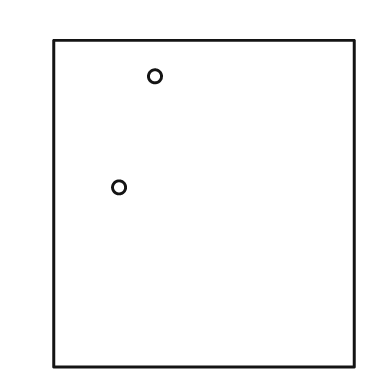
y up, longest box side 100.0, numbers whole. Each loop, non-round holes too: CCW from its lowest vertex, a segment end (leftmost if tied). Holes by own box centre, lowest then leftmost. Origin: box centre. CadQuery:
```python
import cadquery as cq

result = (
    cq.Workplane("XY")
    .moveTo(-46.0, -50.0)
    .lineTo(46.0, -50.0)
    .lineTo(46.0, 50.0)
    .lineTo(-46.0, 50.0)
    .close()
    .moveTo(-26.0, 5.0)
    .circle(2.0)
    .moveTo(-15.0, 39.0)
    .circle(2.0)
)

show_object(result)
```